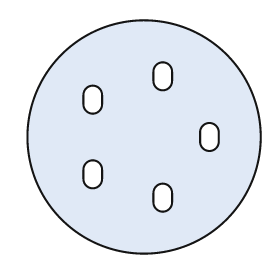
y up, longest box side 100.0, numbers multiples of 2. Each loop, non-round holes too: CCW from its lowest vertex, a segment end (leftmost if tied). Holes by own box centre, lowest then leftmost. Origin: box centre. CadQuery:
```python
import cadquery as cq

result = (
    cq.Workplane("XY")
    .moveTo(0.0, 0.0)
    .circle(50.0)
    .moveTo(4.0, -28.0)
    .threePointArc((8.0, -32.0), (12.0, -28.0))
    .lineTo(12.0, -24.0)
    .threePointArc((8.0, -20.0), (4.0, -24.0))
    .close()
    .moveTo(-26.0, -18.0)
    .threePointArc((-22.0, -22.0), (-18.0, -18.0))
    .lineTo(-18.0, -14.0)
    .threePointArc((-22.0, -10.0), (-26.0, -14.0))
    .close()
    .moveTo(24.0, -2.0)
    .threePointArc((28.0, -6.0), (32.0, -2.0))
    .lineTo(32.0, 2.0)
    .threePointArc((28.0, 6.0), (24.0, 2.0))
    .close()
    .moveTo(-26.0, 14.0)
    .threePointArc((-22.0, 10.0), (-18.0, 14.0))
    .lineTo(-18.0, 18.0)
    .threePointArc((-22.0, 22.0), (-26.0, 18.0))
    .close()
    .moveTo(4.0, 24.0)
    .threePointArc((8.0, 20.0), (12.0, 24.0))
    .lineTo(12.0, 28.0)
    .threePointArc((8.0, 32.0), (4.0, 28.0))
    .close()
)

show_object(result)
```